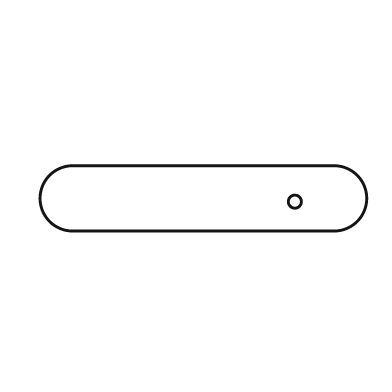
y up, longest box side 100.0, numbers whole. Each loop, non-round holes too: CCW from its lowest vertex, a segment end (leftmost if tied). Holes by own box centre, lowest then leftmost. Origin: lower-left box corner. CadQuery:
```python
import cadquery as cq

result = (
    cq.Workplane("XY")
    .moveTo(10.0, 0.0)
    .lineTo(90.0, 0.0)
    .threePointArc((100.0, 10.0), (90.0, 20.0))
    .lineTo(10.0, 20.0)
    .threePointArc((0.0, 10.0), (10.0, 0.0))
    .close()
    .moveTo(78.0, 9.0)
    .circle(2.0)
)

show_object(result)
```